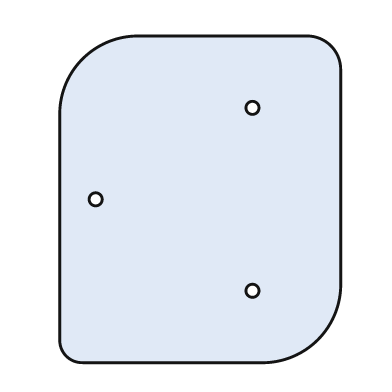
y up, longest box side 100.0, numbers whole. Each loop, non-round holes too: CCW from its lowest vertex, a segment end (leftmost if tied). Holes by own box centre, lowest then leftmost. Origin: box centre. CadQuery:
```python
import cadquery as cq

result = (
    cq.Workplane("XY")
    .moveTo(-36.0, -50.0)
    .lineTo(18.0, -50.0)
    .threePointArc((36.0, -43.0), (43.0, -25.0))
    .lineTo(43.0, 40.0)
    .threePointArc((40.0, 47.0), (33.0, 50.0))
    .lineTo(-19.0, 50.0)
    .threePointArc((-36.0, 43.0), (-43.0, 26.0))
    .lineTo(-43.0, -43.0)
    .threePointArc((-41.0, -48.0), (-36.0, -50.0))
    .close()
    .moveTo(16.0, -28.0)
    .circle(2.0)
    .moveTo(-32.0, 0.0)
    .circle(2.0)
    .moveTo(16.0, 28.0)
    .circle(2.0)
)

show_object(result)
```